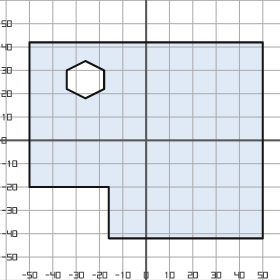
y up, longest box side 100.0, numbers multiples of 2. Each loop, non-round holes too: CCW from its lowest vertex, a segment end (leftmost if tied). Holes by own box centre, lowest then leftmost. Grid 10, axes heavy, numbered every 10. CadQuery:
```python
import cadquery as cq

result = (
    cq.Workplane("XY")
    .moveTo(-16.0, -42.0)
    .lineTo(50.0, -42.0)
    .lineTo(50.0, 42.0)
    .lineTo(-50.0, 42.0)
    .lineTo(-50.0, -20.0)
    .lineTo(-16.0, -20.0)
    .close()
    .moveTo(-26.0, 18.0)
    .lineTo(-18.0, 22.0)
    .lineTo(-18.0, 30.0)
    .lineTo(-26.0, 34.0)
    .lineTo(-34.0, 30.0)
    .lineTo(-34.0, 22.0)
    .close()
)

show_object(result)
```